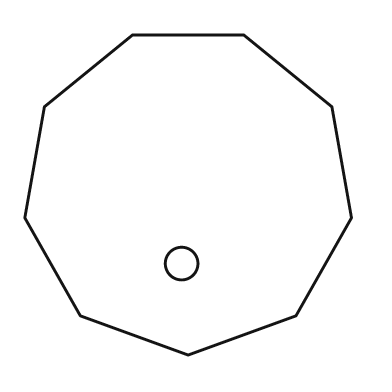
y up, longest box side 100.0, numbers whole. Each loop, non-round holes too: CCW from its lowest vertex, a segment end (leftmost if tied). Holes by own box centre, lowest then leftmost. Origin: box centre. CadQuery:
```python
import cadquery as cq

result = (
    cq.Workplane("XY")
    .moveTo(0.0, -49.0)
    .lineTo(33.0, -37.0)
    .lineTo(50.0, -7.0)
    .lineTo(44.0, 27.0)
    .lineTo(17.0, 49.0)
    .lineTo(-17.0, 49.0)
    .lineTo(-44.0, 27.0)
    .lineTo(-50.0, -7.0)
    .lineTo(-33.0, -37.0)
    .close()
    .moveTo(-2.0, -21.0)
    .circle(5.0)
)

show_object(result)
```